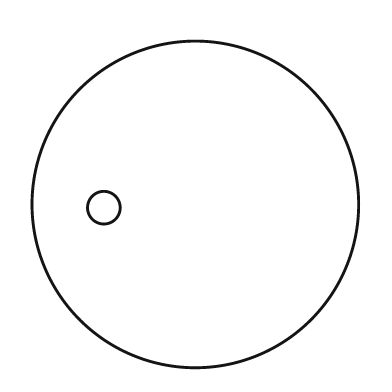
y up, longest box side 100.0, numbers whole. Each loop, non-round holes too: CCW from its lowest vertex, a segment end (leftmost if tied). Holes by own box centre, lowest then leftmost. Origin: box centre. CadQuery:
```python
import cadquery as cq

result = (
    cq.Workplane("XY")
    .moveTo(0.0, 0.0)
    .circle(50.0)
    .moveTo(-28.0, -1.0)
    .circle(5.0)
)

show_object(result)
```